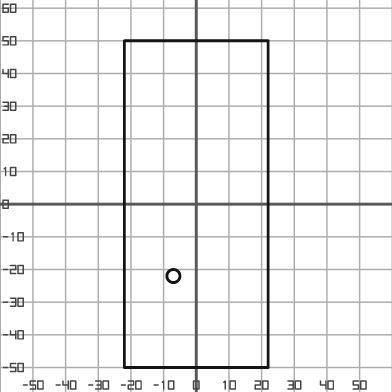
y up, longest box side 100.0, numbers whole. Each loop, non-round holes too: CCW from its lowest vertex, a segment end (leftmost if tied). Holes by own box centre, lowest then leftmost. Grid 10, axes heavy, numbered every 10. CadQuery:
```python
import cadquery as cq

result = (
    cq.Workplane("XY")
    .moveTo(-22.0, -50.0)
    .lineTo(22.0, -50.0)
    .lineTo(22.0, 50.0)
    .lineTo(-22.0, 50.0)
    .close()
    .moveTo(-7.0, -22.0)
    .circle(2.0)
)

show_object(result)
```